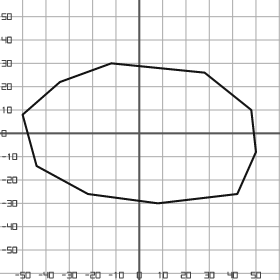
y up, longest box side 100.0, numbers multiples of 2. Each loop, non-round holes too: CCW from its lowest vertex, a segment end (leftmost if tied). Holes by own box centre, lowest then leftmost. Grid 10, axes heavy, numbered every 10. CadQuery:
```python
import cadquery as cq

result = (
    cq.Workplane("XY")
    .moveTo(8.0, -30.0)
    .lineTo(42.0, -26.0)
    .lineTo(50.0, -8.0)
    .lineTo(48.0, 10.0)
    .lineTo(28.0, 26.0)
    .lineTo(-12.0, 30.0)
    .lineTo(-34.0, 22.0)
    .lineTo(-50.0, 8.0)
    .lineTo(-44.0, -14.0)
    .lineTo(-22.0, -26.0)
    .close()
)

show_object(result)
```